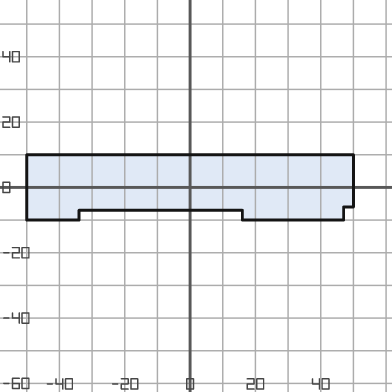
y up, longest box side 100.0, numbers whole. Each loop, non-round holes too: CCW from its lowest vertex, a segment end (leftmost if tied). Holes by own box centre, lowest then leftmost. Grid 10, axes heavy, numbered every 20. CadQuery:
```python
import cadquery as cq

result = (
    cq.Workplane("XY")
    .moveTo(-50.0, -10.0)
    .lineTo(-34.0, -10.0)
    .lineTo(-34.0, -7.0)
    .lineTo(16.0, -7.0)
    .lineTo(16.0, -10.0)
    .lineTo(47.0, -10.0)
    .lineTo(47.0, -6.0)
    .lineTo(50.0, -6.0)
    .lineTo(50.0, 10.0)
    .lineTo(-50.0, 10.0)
    .close()
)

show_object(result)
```